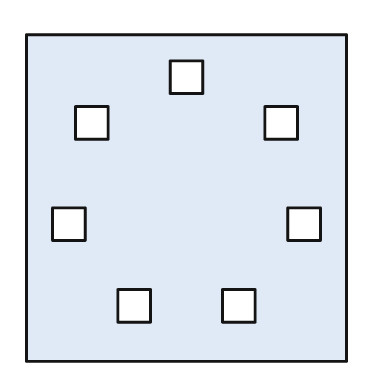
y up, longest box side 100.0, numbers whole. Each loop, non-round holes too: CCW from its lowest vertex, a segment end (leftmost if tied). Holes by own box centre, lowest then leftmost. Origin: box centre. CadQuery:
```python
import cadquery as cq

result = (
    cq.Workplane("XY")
    .moveTo(-49.0, -50.0)
    .lineTo(49.0, -50.0)
    .lineTo(49.0, 50.0)
    .lineTo(-49.0, 50.0)
    .close()
    .moveTo(-21.0, -38.0)
    .lineTo(-11.0, -38.0)
    .lineTo(-11.0, -28.0)
    .lineTo(-21.0, -28.0)
    .close()
    .moveTo(11.0, -38.0)
    .lineTo(21.0, -38.0)
    .lineTo(21.0, -28.0)
    .lineTo(11.0, -28.0)
    .close()
    .moveTo(-41.0, -13.0)
    .lineTo(-31.0, -13.0)
    .lineTo(-31.0, -3.0)
    .lineTo(-41.0, -3.0)
    .close()
    .moveTo(31.0, -13.0)
    .lineTo(41.0, -13.0)
    .lineTo(41.0, -3.0)
    .lineTo(31.0, -3.0)
    .close()
    .moveTo(-34.0, 18.0)
    .lineTo(-24.0, 18.0)
    .lineTo(-24.0, 28.0)
    .lineTo(-34.0, 28.0)
    .close()
    .moveTo(24.0, 18.0)
    .lineTo(34.0, 18.0)
    .lineTo(34.0, 28.0)
    .lineTo(24.0, 28.0)
    .close()
    .moveTo(-5.0, 32.0)
    .lineTo(5.0, 32.0)
    .lineTo(5.0, 42.0)
    .lineTo(-5.0, 42.0)
    .close()
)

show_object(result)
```